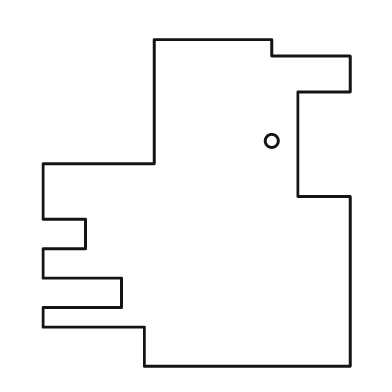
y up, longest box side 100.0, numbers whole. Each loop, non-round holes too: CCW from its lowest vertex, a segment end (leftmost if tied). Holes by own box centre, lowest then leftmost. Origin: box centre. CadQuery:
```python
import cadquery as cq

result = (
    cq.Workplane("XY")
    .moveTo(-16.0, -50.0)
    .lineTo(47.0, -50.0)
    .lineTo(47.0, 2.0)
    .lineTo(31.0, 2.0)
    .lineTo(31.0, 34.0)
    .lineTo(47.0, 34.0)
    .lineTo(47.0, 45.0)
    .lineTo(23.0, 45.0)
    .lineTo(23.0, 50.0)
    .lineTo(-13.0, 50.0)
    .lineTo(-13.0, 12.0)
    .lineTo(-47.0, 12.0)
    .lineTo(-47.0, -5.0)
    .lineTo(-34.0, -5.0)
    .lineTo(-34.0, -14.0)
    .lineTo(-47.0, -14.0)
    .lineTo(-47.0, -23.0)
    .lineTo(-23.0, -23.0)
    .lineTo(-23.0, -32.0)
    .lineTo(-47.0, -32.0)
    .lineTo(-47.0, -38.0)
    .lineTo(-16.0, -38.0)
    .close()
    .moveTo(23.0, 19.0)
    .circle(2.0)
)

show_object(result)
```